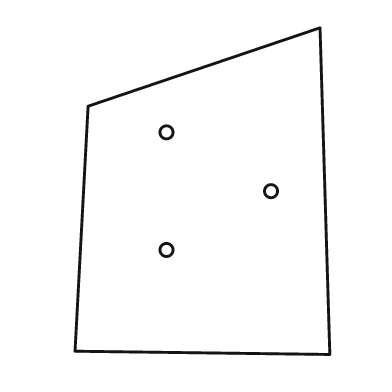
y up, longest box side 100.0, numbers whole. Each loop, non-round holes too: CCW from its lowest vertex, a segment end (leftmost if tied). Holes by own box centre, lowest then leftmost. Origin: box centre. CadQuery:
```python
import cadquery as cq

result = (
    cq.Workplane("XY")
    .moveTo(39.0, -50.0)
    .lineTo(36.0, 50.0)
    .lineTo(-35.0, 26.0)
    .lineTo(-39.0, -49.0)
    .close()
    .moveTo(-11.0, -18.0)
    .circle(2.0)
    .moveTo(21.0, 0.0)
    .circle(2.0)
    .moveTo(-11.0, 18.0)
    .circle(2.0)
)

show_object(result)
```